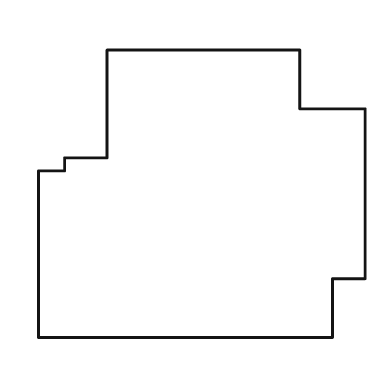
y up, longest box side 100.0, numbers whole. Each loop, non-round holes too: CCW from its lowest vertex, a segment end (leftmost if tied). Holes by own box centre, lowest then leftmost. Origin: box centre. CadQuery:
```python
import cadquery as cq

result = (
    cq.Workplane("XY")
    .moveTo(-50.0, -44.0)
    .lineTo(40.0, -44.0)
    .lineTo(40.0, -26.0)
    .lineTo(50.0, -26.0)
    .lineTo(50.0, 26.0)
    .lineTo(30.0, 26.0)
    .lineTo(30.0, 44.0)
    .lineTo(-29.0, 44.0)
    .lineTo(-29.0, 11.0)
    .lineTo(-42.0, 11.0)
    .lineTo(-42.0, 7.0)
    .lineTo(-50.0, 7.0)
    .close()
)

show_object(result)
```